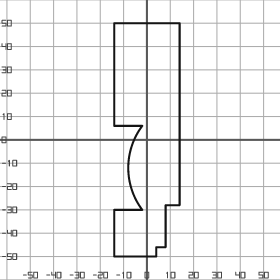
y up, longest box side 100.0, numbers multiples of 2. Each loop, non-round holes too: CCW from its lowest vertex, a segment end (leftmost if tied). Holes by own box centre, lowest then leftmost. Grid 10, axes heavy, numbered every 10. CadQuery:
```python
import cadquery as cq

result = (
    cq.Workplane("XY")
    .moveTo(-14.0, -50.0)
    .lineTo(4.0, -50.0)
    .lineTo(4.0, -46.0)
    .lineTo(8.0, -46.0)
    .lineTo(8.0, -28.0)
    .lineTo(14.0, -28.0)
    .lineTo(14.0, 50.0)
    .lineTo(-14.0, 50.0)
    .lineTo(-14.0, 6.0)
    .lineTo(-2.0, 6.0)
    .threePointArc((-8.0, -12.0), (-2.0, -30.0))
    .lineTo(-14.0, -30.0)
    .close()
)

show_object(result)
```